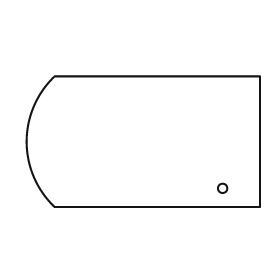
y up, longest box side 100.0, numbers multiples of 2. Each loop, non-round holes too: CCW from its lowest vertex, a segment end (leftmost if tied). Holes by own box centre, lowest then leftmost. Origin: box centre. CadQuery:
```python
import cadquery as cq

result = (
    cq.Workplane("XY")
    .moveTo(-38.0, -28.0)
    .lineTo(50.0, -28.0)
    .lineTo(50.0, 28.0)
    .lineTo(-38.0, 28.0)
    .threePointArc((-50.0, 0.0), (-38.0, -28.0))
    .close()
    .moveTo(34.0, -20.0)
    .circle(2.0)
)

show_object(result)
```